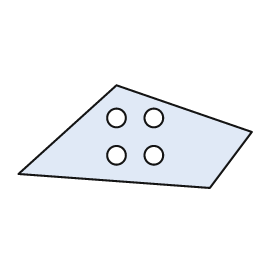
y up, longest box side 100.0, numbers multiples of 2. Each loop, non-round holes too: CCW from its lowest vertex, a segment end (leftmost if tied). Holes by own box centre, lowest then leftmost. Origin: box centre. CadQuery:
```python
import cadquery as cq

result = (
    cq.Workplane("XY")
    .moveTo(32.0, -22.0)
    .lineTo(50.0, 2.0)
    .lineTo(-8.0, 22.0)
    .lineTo(-50.0, -16.0)
    .close()
    .moveTo(-8.0, -8.0)
    .circle(4.0)
    .moveTo(8.0, -8.0)
    .circle(4.0)
    .moveTo(-8.0, 8.0)
    .circle(4.0)
    .moveTo(8.0, 8.0)
    .circle(4.0)
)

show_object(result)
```